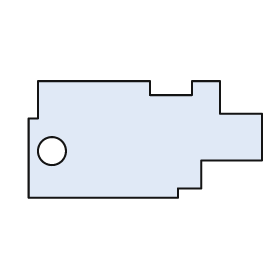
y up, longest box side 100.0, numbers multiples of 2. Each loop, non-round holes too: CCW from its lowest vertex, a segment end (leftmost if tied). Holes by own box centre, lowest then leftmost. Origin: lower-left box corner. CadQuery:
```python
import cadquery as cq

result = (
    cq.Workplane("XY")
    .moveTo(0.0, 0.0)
    .lineTo(64.0, 0.0)
    .lineTo(64.0, 4.0)
    .lineTo(74.0, 4.0)
    .lineTo(74.0, 16.0)
    .lineTo(100.0, 16.0)
    .lineTo(100.0, 36.0)
    .lineTo(82.0, 36.0)
    .lineTo(82.0, 50.0)
    .lineTo(70.0, 50.0)
    .lineTo(70.0, 44.0)
    .lineTo(52.0, 44.0)
    .lineTo(52.0, 50.0)
    .lineTo(4.0, 50.0)
    .lineTo(4.0, 34.0)
    .lineTo(0.0, 34.0)
    .close()
    .moveTo(10.0, 20.0)
    .circle(6.0)
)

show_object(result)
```